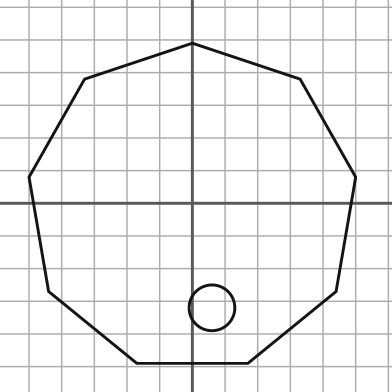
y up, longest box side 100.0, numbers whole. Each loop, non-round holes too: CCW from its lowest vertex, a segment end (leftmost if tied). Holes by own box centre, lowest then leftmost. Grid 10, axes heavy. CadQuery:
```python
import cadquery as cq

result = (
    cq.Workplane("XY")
    .moveTo(-17.0, -49.0)
    .lineTo(17.0, -49.0)
    .lineTo(44.0, -27.0)
    .lineTo(50.0, 8.0)
    .lineTo(33.0, 38.0)
    .lineTo(0.0, 49.0)
    .lineTo(-33.0, 38.0)
    .lineTo(-50.0, 8.0)
    .lineTo(-44.0, -27.0)
    .close()
    .moveTo(6.0, -32.0)
    .circle(7.0)
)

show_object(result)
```